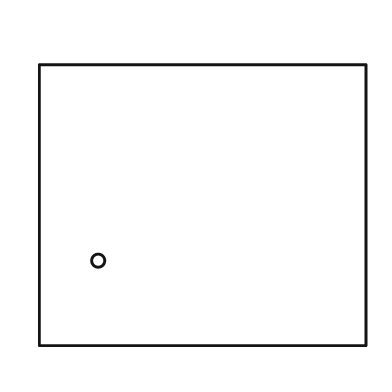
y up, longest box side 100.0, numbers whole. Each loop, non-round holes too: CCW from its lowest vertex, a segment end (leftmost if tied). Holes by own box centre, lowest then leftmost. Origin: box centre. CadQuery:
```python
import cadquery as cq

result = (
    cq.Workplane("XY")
    .moveTo(-50.0, -43.0)
    .lineTo(50.0, -43.0)
    .lineTo(50.0, 43.0)
    .lineTo(-50.0, 43.0)
    .close()
    .moveTo(-32.0, -17.0)
    .circle(2.0)
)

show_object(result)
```